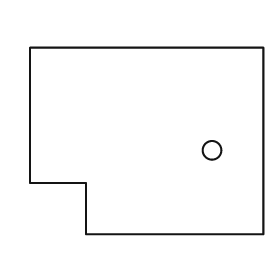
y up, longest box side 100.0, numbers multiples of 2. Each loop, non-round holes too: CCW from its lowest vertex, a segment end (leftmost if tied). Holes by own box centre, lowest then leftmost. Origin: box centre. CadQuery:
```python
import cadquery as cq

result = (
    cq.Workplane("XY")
    .moveTo(-26.0, -40.0)
    .lineTo(50.0, -40.0)
    .lineTo(50.0, 40.0)
    .lineTo(-50.0, 40.0)
    .lineTo(-50.0, -18.0)
    .lineTo(-26.0, -18.0)
    .close()
    .moveTo(28.0, -4.0)
    .circle(4.0)
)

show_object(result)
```